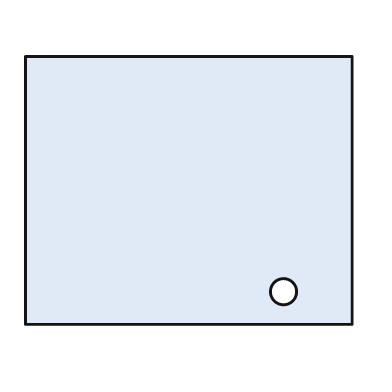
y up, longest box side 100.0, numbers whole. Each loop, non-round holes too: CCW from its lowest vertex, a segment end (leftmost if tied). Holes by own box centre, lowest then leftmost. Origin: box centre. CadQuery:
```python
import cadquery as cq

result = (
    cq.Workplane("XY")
    .moveTo(-50.0, -41.0)
    .lineTo(50.0, -41.0)
    .lineTo(50.0, 41.0)
    .lineTo(-50.0, 41.0)
    .close()
    .moveTo(29.0, -31.0)
    .circle(4.0)
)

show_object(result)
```